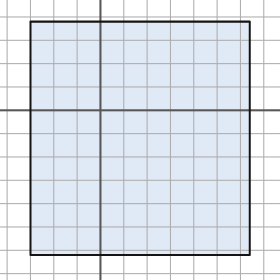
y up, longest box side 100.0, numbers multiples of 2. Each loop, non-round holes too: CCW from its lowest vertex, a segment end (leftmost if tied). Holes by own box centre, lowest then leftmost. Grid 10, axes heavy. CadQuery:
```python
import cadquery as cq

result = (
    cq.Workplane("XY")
    .moveTo(-30.0, -62.0)
    .lineTo(64.0, -62.0)
    .lineTo(64.0, 38.0)
    .lineTo(-30.0, 38.0)
    .close()
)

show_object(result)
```